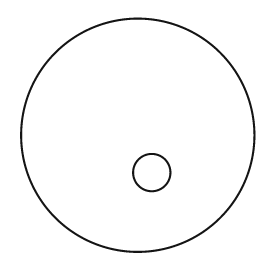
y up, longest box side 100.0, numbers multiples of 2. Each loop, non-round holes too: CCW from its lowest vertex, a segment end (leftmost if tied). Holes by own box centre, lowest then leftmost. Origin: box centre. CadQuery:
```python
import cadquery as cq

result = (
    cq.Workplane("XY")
    .moveTo(0.0, 0.0)
    .circle(50.0)
    .moveTo(6.0, -16.0)
    .circle(8.0)
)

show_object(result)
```